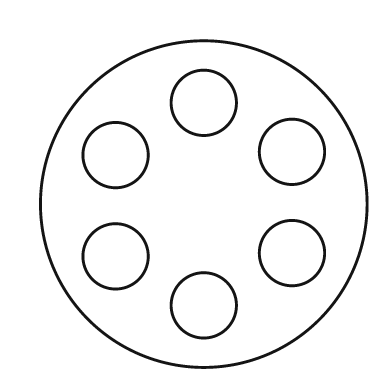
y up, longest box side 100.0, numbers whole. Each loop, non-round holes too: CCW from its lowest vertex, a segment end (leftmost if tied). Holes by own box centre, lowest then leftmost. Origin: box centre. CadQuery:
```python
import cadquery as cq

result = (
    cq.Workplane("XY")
    .moveTo(0.0, 0.0)
    .circle(50.0)
    .moveTo(0.0, -31.0)
    .circle(10.0)
    .moveTo(-27.0, -16.0)
    .circle(10.0)
    .moveTo(27.0, -15.0)
    .circle(10.0)
    .moveTo(-27.0, 15.0)
    .circle(10.0)
    .moveTo(27.0, 16.0)
    .circle(10.0)
    .moveTo(0.0, 31.0)
    .circle(10.0)
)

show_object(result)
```